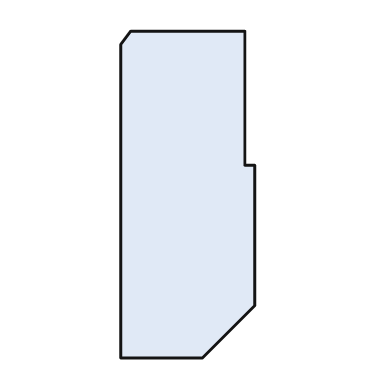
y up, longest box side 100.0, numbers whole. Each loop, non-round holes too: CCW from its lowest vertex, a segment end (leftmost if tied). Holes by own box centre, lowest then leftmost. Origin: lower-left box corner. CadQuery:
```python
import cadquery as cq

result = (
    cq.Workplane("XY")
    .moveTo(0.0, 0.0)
    .lineTo(25.0, 0.0)
    .lineTo(41.0, 16.0)
    .lineTo(41.0, 59.0)
    .lineTo(38.0, 59.0)
    .lineTo(38.0, 100.0)
    .lineTo(3.0, 100.0)
    .lineTo(0.0, 96.0)
    .close()
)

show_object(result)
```